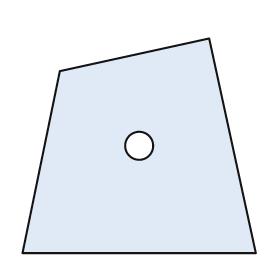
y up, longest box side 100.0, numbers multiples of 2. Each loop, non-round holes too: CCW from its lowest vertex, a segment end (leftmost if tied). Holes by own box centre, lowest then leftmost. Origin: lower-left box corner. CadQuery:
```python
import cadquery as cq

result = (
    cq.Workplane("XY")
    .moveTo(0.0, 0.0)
    .lineTo(100.0, 0.0)
    .lineTo(80.0, 92.0)
    .lineTo(16.0, 78.0)
    .close()
    .moveTo(50.0, 46.0)
    .circle(6.0)
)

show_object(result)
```